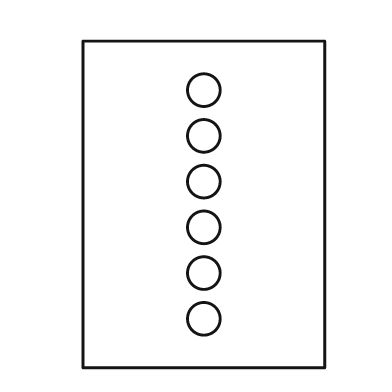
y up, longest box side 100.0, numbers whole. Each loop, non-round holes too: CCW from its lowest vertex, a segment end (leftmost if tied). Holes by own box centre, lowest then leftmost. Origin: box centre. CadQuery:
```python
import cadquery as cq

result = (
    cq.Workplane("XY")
    .moveTo(-37.0, -50.0)
    .lineTo(37.0, -50.0)
    .lineTo(37.0, 50.0)
    .lineTo(-37.0, 50.0)
    .close()
    .moveTo(0.0, -35.0)
    .circle(5.0)
    .moveTo(0.0, -21.0)
    .circle(5.0)
    .moveTo(0.0, -7.0)
    .circle(5.0)
    .moveTo(0.0, 7.0)
    .circle(5.0)
    .moveTo(0.0, 21.0)
    .circle(5.0)
    .moveTo(0.0, 35.0)
    .circle(5.0)
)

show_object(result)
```